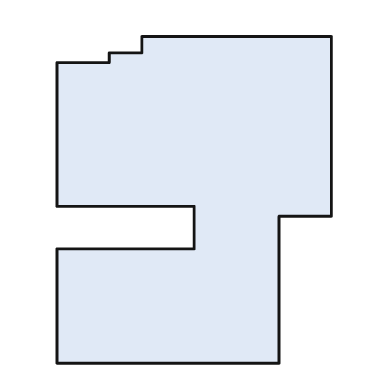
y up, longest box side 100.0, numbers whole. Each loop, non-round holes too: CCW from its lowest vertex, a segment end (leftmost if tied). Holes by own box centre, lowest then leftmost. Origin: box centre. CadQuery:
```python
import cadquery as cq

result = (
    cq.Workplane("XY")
    .moveTo(-42.0, -50.0)
    .lineTo(26.0, -50.0)
    .lineTo(26.0, -5.0)
    .lineTo(42.0, -5.0)
    .lineTo(42.0, 50.0)
    .lineTo(-16.0, 50.0)
    .lineTo(-16.0, 45.0)
    .lineTo(-26.0, 45.0)
    .lineTo(-26.0, 42.0)
    .lineTo(-42.0, 42.0)
    .lineTo(-42.0, -2.0)
    .lineTo(0.0, -2.0)
    .lineTo(0.0, -15.0)
    .lineTo(-42.0, -15.0)
    .close()
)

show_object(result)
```